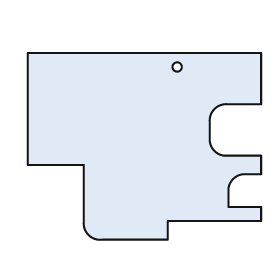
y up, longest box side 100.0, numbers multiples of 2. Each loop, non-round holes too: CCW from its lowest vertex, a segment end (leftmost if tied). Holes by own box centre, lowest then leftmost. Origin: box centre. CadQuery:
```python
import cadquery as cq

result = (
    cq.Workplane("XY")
    .moveTo(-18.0, -40.0)
    .lineTo(10.0, -40.0)
    .lineTo(10.0, -32.0)
    .lineTo(50.0, -32.0)
    .lineTo(50.0, -26.0)
    .lineTo(36.0, -26.0)
    .lineTo(36.0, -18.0)
    .threePointArc((38.0, -14.0), (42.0, -12.0))
    .lineTo(50.0, -12.0)
    .lineTo(50.0, -4.0)
    .lineTo(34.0, -4.0)
    .threePointArc((30.0, -2.0), (28.0, 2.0))
    .lineTo(28.0, 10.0)
    .threePointArc((30.0, 16.0), (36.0, 18.0))
    .lineTo(50.0, 18.0)
    .lineTo(50.0, 40.0)
    .lineTo(-50.0, 40.0)
    .lineTo(-50.0, -8.0)
    .lineTo(-26.0, -8.0)
    .lineTo(-26.0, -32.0)
    .threePointArc((-24.0, -38.0), (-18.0, -40.0))
    .close()
    .moveTo(14.0, 34.0)
    .circle(2.0)
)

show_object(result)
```